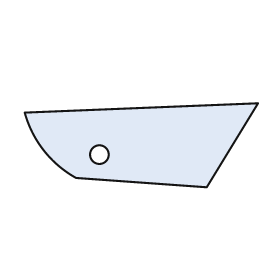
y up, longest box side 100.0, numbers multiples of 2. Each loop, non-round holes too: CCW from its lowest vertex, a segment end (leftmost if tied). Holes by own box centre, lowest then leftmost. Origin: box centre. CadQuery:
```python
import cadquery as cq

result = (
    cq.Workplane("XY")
    .moveTo(28.0, -18.0)
    .lineTo(50.0, 18.0)
    .lineTo(-50.0, 14.0)
    .threePointArc((-42.0, -2.0), (-28.0, -14.0))
    .close()
    .moveTo(-18.0, -4.0)
    .circle(4.0)
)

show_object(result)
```